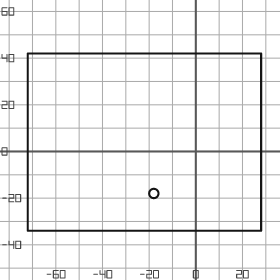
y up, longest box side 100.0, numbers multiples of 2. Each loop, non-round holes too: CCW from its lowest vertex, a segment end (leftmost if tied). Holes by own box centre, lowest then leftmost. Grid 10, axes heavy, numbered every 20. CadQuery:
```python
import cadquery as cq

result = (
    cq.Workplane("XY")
    .moveTo(-72.0, -34.0)
    .lineTo(28.0, -34.0)
    .lineTo(28.0, 42.0)
    .lineTo(-72.0, 42.0)
    .close()
    .moveTo(-18.0, -18.0)
    .circle(2.0)
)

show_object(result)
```